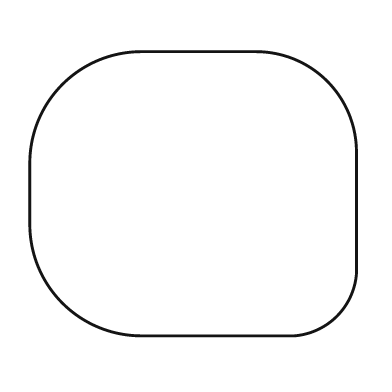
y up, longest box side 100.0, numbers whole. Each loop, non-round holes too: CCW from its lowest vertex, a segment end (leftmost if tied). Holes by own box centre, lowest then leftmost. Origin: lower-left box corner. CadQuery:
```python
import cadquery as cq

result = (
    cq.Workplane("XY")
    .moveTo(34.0, 0.0)
    .lineTo(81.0, 0.0)
    .threePointArc((94.0, 6.0), (100.0, 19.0))
    .lineTo(100.0, 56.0)
    .threePointArc((91.0, 78.0), (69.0, 87.0))
    .lineTo(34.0, 87.0)
    .threePointArc((10.0, 77.0), (0.0, 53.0))
    .lineTo(0.0, 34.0)
    .threePointArc((10.0, 10.0), (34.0, 0.0))
    .close()
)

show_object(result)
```